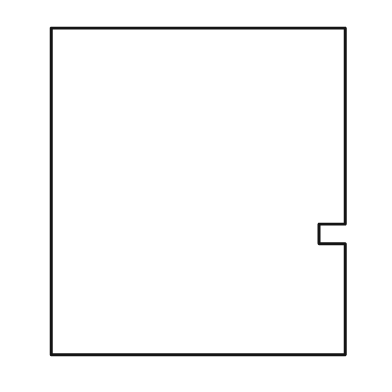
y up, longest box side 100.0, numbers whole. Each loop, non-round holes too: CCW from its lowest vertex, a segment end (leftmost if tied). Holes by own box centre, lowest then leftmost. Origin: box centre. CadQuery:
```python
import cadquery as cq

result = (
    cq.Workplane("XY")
    .moveTo(-45.0, -50.0)
    .lineTo(45.0, -50.0)
    .lineTo(45.0, -16.0)
    .lineTo(37.0, -16.0)
    .lineTo(37.0, -10.0)
    .lineTo(45.0, -10.0)
    .lineTo(45.0, 50.0)
    .lineTo(-45.0, 50.0)
    .close()
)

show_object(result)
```